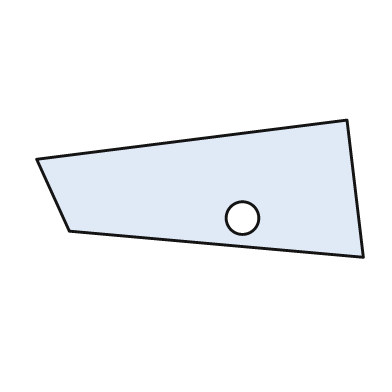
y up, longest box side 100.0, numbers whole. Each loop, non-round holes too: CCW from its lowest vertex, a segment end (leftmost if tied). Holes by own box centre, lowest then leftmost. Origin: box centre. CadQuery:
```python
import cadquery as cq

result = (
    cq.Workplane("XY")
    .moveTo(50.0, -21.0)
    .lineTo(45.0, 21.0)
    .lineTo(-50.0, 9.0)
    .lineTo(-40.0, -13.0)
    .close()
    .moveTo(13.0, -9.0)
    .circle(5.0)
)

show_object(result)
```